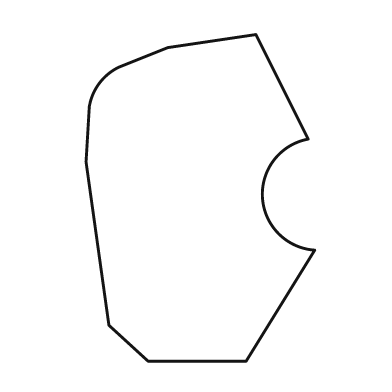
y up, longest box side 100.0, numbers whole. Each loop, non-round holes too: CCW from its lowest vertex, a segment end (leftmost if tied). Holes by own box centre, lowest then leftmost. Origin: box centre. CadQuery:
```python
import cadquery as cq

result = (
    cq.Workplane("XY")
    .moveTo(-16.0, -50.0)
    .lineTo(14.0, -50.0)
    .lineTo(35.0, -16.0)
    .threePointArc((19.0, 0.0), (33.0, 18.0))
    .lineTo(17.0, 50.0)
    .lineTo(-10.0, 46.0)
    .lineTo(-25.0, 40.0)
    .threePointArc((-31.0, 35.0), (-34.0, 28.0))
    .lineTo(-35.0, 11.0)
    .lineTo(-28.0, -39.0)
    .close()
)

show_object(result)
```